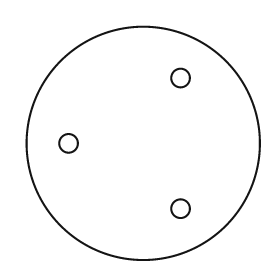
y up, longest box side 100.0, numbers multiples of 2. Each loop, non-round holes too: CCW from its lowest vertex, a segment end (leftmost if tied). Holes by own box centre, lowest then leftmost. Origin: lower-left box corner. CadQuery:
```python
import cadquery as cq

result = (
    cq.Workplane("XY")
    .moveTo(50.0, 50.0)
    .circle(50.0)
    .moveTo(66.0, 22.0)
    .circle(4.0)
    .moveTo(18.0, 50.0)
    .circle(4.0)
    .moveTo(66.0, 78.0)
    .circle(4.0)
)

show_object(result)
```